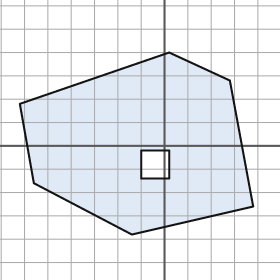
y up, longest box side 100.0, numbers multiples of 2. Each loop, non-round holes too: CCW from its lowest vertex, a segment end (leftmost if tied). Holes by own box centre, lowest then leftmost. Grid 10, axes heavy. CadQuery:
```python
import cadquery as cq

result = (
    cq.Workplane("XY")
    .moveTo(-14.0, -38.0)
    .lineTo(38.0, -26.0)
    .lineTo(28.0, 28.0)
    .lineTo(2.0, 40.0)
    .lineTo(-62.0, 18.0)
    .lineTo(-56.0, -16.0)
    .close()
    .moveTo(-10.0, -14.0)
    .lineTo(2.0, -14.0)
    .lineTo(2.0, -2.0)
    .lineTo(-10.0, -2.0)
    .close()
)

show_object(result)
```